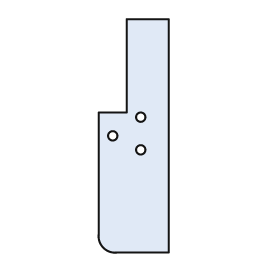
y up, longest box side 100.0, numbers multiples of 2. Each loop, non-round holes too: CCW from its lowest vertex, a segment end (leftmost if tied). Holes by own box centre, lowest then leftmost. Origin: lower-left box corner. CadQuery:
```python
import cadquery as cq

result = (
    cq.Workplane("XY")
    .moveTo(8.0, 0.0)
    .lineTo(30.0, 0.0)
    .lineTo(30.0, 100.0)
    .lineTo(12.0, 100.0)
    .lineTo(12.0, 60.0)
    .lineTo(0.0, 60.0)
    .lineTo(0.0, 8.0)
    .threePointArc((2.0, 2.0), (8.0, 0.0))
    .close()
    .moveTo(18.0, 44.0)
    .circle(2.0)
    .moveTo(6.0, 50.0)
    .circle(2.0)
    .moveTo(18.0, 58.0)
    .circle(2.0)
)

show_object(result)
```